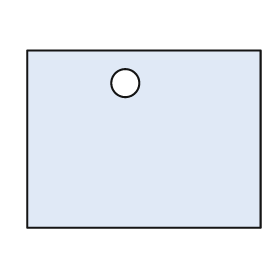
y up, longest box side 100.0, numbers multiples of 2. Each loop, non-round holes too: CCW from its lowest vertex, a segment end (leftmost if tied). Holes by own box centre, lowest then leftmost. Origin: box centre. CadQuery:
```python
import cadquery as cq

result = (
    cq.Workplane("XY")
    .moveTo(-50.0, -38.0)
    .lineTo(50.0, -38.0)
    .lineTo(50.0, 38.0)
    .lineTo(-50.0, 38.0)
    .close()
    .moveTo(-8.0, 24.0)
    .circle(6.0)
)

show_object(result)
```